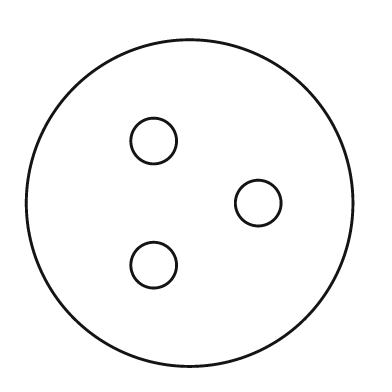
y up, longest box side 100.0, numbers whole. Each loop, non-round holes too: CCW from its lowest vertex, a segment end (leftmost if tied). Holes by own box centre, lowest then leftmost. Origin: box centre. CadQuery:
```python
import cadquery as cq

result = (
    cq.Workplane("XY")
    .moveTo(0.0, 0.0)
    .circle(50.0)
    .moveTo(-11.0, -19.0)
    .circle(7.0)
    .moveTo(21.0, 0.0)
    .circle(7.0)
    .moveTo(-11.0, 19.0)
    .circle(7.0)
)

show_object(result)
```